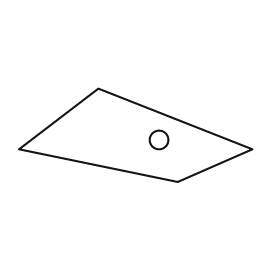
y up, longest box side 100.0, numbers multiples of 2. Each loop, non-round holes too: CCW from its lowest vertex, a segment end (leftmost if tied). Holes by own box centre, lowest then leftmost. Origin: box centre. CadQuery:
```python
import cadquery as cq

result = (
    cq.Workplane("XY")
    .moveTo(18.0, -20.0)
    .lineTo(50.0, -6.0)
    .lineTo(-16.0, 20.0)
    .lineTo(-50.0, -6.0)
    .close()
    .moveTo(10.0, -2.0)
    .circle(4.0)
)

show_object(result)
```